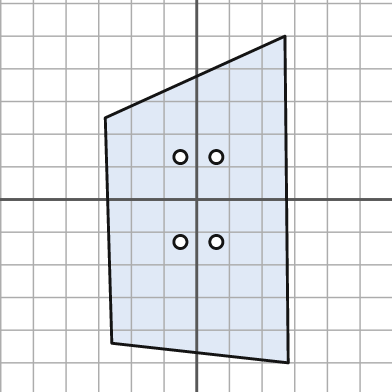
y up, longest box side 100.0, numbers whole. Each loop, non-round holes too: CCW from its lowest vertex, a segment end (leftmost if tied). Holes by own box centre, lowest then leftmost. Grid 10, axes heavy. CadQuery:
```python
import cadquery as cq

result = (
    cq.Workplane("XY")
    .moveTo(28.0, -50.0)
    .lineTo(27.0, 50.0)
    .lineTo(-28.0, 25.0)
    .lineTo(-26.0, -44.0)
    .close()
    .moveTo(-5.0, -13.0)
    .circle(2.0)
    .moveTo(6.0, -13.0)
    .circle(2.0)
    .moveTo(-5.0, 13.0)
    .circle(2.0)
    .moveTo(6.0, 13.0)
    .circle(2.0)
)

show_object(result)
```